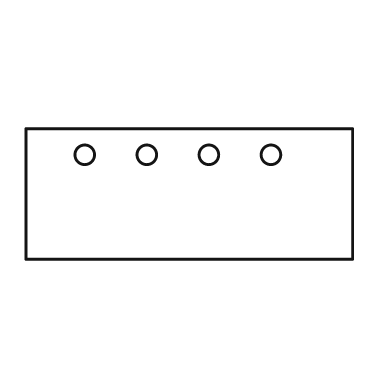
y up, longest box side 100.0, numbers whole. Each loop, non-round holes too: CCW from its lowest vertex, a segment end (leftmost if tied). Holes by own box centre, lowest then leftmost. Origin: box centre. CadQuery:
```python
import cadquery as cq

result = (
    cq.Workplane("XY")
    .moveTo(-50.0, -20.0)
    .lineTo(50.0, -20.0)
    .lineTo(50.0, 20.0)
    .lineTo(-50.0, 20.0)
    .close()
    .moveTo(-32.0, 12.0)
    .circle(3.0)
    .moveTo(-13.0, 12.0)
    .circle(3.0)
    .moveTo(6.0, 12.0)
    .circle(3.0)
    .moveTo(25.0, 12.0)
    .circle(3.0)
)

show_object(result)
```